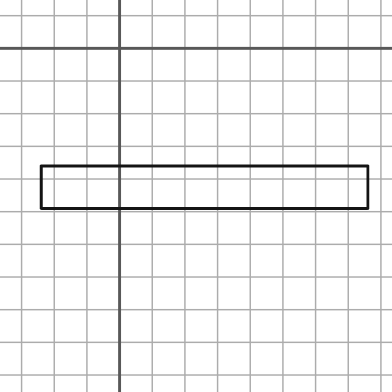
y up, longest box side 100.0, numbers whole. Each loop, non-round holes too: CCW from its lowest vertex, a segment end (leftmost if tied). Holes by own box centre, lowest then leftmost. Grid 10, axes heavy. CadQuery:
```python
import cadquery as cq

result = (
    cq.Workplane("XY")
    .moveTo(-24.0, -49.0)
    .lineTo(76.0, -49.0)
    .lineTo(76.0, -36.0)
    .lineTo(-24.0, -36.0)
    .close()
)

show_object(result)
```